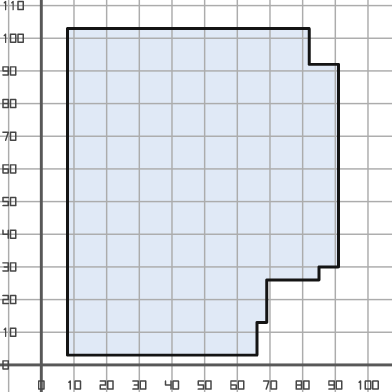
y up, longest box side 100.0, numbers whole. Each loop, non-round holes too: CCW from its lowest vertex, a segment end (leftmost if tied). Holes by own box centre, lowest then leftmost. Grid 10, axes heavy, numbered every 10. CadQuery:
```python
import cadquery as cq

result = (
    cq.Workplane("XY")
    .moveTo(8.0, 3.0)
    .lineTo(66.0, 3.0)
    .lineTo(66.0, 13.0)
    .lineTo(69.0, 13.0)
    .lineTo(69.0, 26.0)
    .lineTo(85.0, 26.0)
    .lineTo(85.0, 30.0)
    .lineTo(91.0, 30.0)
    .lineTo(91.0, 92.0)
    .lineTo(82.0, 92.0)
    .lineTo(82.0, 103.0)
    .lineTo(8.0, 103.0)
    .close()
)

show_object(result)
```